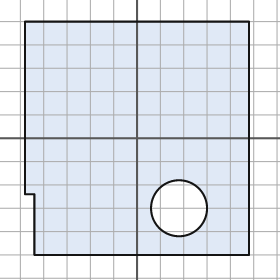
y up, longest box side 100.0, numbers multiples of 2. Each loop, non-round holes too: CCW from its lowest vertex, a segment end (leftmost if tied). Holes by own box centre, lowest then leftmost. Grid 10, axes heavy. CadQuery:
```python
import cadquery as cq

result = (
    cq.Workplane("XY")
    .moveTo(-44.0, -50.0)
    .lineTo(48.0, -50.0)
    .lineTo(48.0, 50.0)
    .lineTo(-48.0, 50.0)
    .lineTo(-48.0, -24.0)
    .lineTo(-44.0, -24.0)
    .close()
    .moveTo(18.0, -30.0)
    .circle(12.0)
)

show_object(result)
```